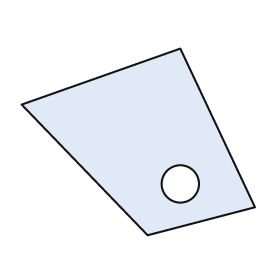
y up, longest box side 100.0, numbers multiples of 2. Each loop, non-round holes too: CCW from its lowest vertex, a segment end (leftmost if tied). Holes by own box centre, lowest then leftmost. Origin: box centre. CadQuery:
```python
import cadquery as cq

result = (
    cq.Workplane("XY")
    .moveTo(4.0, -40.0)
    .lineTo(50.0, -28.0)
    .lineTo(18.0, 40.0)
    .lineTo(-50.0, 16.0)
    .close()
    .moveTo(18.0, -18.0)
    .circle(8.0)
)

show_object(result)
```